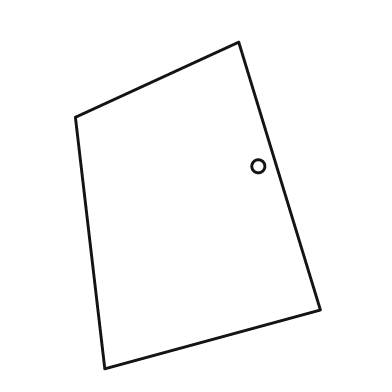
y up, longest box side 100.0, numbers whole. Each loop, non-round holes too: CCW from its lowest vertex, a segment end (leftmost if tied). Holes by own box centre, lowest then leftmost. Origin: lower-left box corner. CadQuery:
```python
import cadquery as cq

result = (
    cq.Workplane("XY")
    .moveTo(9.0, 0.0)
    .lineTo(75.0, 18.0)
    .lineTo(50.0, 100.0)
    .lineTo(0.0, 77.0)
    .close()
    .moveTo(56.0, 62.0)
    .circle(2.0)
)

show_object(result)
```